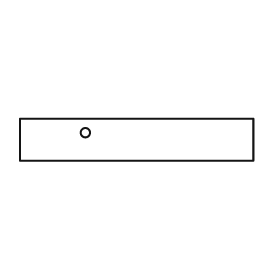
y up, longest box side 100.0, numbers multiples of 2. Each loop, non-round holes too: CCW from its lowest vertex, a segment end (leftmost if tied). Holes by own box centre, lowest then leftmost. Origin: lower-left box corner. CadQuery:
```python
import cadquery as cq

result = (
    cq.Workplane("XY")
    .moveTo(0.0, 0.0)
    .lineTo(100.0, 0.0)
    .lineTo(100.0, 18.0)
    .lineTo(0.0, 18.0)
    .close()
    .moveTo(28.0, 12.0)
    .circle(2.0)
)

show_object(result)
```